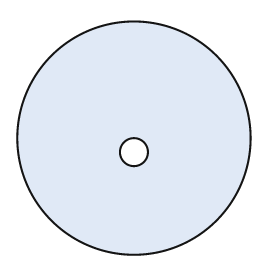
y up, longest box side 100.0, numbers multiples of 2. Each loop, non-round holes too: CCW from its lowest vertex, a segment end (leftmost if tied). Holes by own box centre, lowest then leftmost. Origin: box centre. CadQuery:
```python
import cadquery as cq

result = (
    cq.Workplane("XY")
    .moveTo(0.0, 0.0)
    .circle(50.0)
    .moveTo(0.0, -6.0)
    .circle(6.0)
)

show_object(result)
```